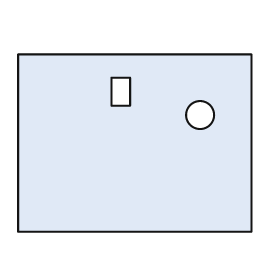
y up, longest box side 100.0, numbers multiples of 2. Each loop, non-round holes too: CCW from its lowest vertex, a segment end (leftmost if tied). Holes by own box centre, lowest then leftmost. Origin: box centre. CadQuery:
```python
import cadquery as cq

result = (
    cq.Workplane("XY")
    .moveTo(-50.0, -38.0)
    .lineTo(50.0, -38.0)
    .lineTo(50.0, 38.0)
    .lineTo(-50.0, 38.0)
    .close()
    .moveTo(28.0, 12.0)
    .circle(6.0)
    .moveTo(-10.0, 16.0)
    .lineTo(-2.0, 16.0)
    .lineTo(-2.0, 28.0)
    .lineTo(-10.0, 28.0)
    .close()
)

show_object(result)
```